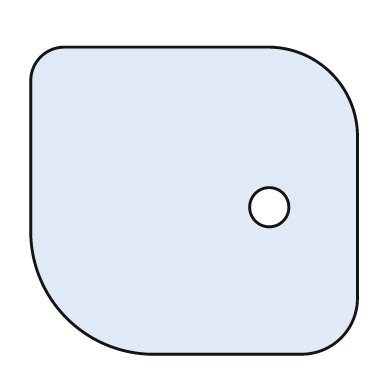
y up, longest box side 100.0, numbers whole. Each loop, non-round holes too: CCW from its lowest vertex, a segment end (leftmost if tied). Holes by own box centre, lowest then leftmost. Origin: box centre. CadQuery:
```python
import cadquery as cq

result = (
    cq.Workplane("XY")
    .moveTo(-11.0, -47.0)
    .lineTo(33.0, -47.0)
    .threePointArc((45.0, -42.0), (50.0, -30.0))
    .lineTo(50.0, 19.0)
    .threePointArc((42.0, 39.0), (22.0, 47.0))
    .lineTo(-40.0, 47.0)
    .threePointArc((-47.0, 44.0), (-50.0, 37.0))
    .lineTo(-50.0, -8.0)
    .threePointArc((-39.0, -36.0), (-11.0, -47.0))
    .close()
    .moveTo(23.0, -2.0)
    .circle(6.0)
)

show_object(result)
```